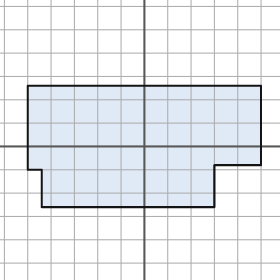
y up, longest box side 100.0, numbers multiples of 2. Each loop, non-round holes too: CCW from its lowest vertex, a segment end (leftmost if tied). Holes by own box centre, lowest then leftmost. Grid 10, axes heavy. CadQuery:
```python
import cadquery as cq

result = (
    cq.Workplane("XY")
    .moveTo(-44.0, -26.0)
    .lineTo(30.0, -26.0)
    .lineTo(30.0, -8.0)
    .lineTo(50.0, -8.0)
    .lineTo(50.0, 26.0)
    .lineTo(-50.0, 26.0)
    .lineTo(-50.0, -10.0)
    .lineTo(-44.0, -10.0)
    .close()
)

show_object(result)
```